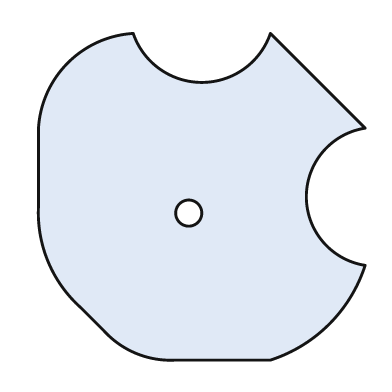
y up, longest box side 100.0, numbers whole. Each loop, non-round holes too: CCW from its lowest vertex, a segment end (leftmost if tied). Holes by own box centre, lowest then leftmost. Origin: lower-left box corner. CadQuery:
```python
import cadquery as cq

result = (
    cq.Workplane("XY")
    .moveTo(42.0, 0.0)
    .lineTo(71.0, 0.0)
    .threePointArc((89.0, 11.0), (100.0, 29.0))
    .threePointArc((82.0, 50.0), (100.0, 71.0))
    .lineTo(71.0, 100.0)
    .threePointArc((50.0, 85.0), (29.0, 100.0))
    .threePointArc((9.0, 91.0), (0.0, 71.0))
    .lineTo(0.0, 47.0)
    .threePointArc((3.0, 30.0), (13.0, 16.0))
    .lineTo(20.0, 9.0)
    .threePointArc((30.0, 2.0), (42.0, 0.0))
    .close()
    .moveTo(46.0, 45.0)
    .circle(4.0)
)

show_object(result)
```